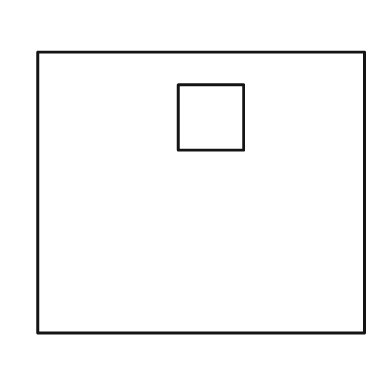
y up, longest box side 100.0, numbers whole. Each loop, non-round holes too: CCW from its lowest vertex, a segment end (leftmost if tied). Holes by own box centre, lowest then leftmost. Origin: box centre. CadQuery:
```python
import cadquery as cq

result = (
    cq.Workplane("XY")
    .moveTo(-50.0, -43.0)
    .lineTo(50.0, -43.0)
    .lineTo(50.0, 43.0)
    .lineTo(-50.0, 43.0)
    .close()
    .moveTo(-7.0, 13.0)
    .lineTo(13.0, 13.0)
    .lineTo(13.0, 33.0)
    .lineTo(-7.0, 33.0)
    .close()
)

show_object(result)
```